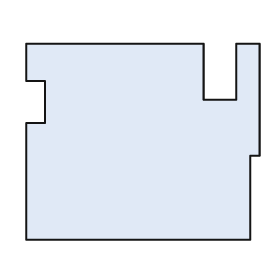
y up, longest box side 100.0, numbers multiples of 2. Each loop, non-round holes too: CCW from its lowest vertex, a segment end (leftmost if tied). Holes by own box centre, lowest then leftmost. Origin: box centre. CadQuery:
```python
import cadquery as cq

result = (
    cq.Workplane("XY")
    .moveTo(-50.0, -42.0)
    .lineTo(46.0, -42.0)
    .lineTo(46.0, -6.0)
    .lineTo(50.0, -6.0)
    .lineTo(50.0, 42.0)
    .lineTo(40.0, 42.0)
    .lineTo(40.0, 18.0)
    .lineTo(26.0, 18.0)
    .lineTo(26.0, 42.0)
    .lineTo(-50.0, 42.0)
    .lineTo(-50.0, 26.0)
    .lineTo(-42.0, 26.0)
    .lineTo(-42.0, 8.0)
    .lineTo(-50.0, 8.0)
    .close()
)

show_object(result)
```